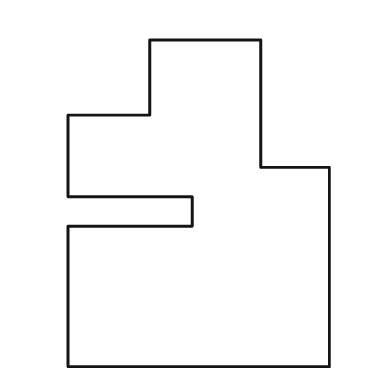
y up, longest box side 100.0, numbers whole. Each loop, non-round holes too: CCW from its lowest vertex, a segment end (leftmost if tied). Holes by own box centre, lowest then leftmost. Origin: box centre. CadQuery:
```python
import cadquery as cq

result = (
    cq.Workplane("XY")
    .moveTo(-40.0, -50.0)
    .lineTo(40.0, -50.0)
    .lineTo(40.0, 11.0)
    .lineTo(19.0, 11.0)
    .lineTo(19.0, 50.0)
    .lineTo(-15.0, 50.0)
    .lineTo(-15.0, 27.0)
    .lineTo(-40.0, 27.0)
    .lineTo(-40.0, 2.0)
    .lineTo(-2.0, 2.0)
    .lineTo(-2.0, -7.0)
    .lineTo(-40.0, -7.0)
    .close()
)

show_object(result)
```